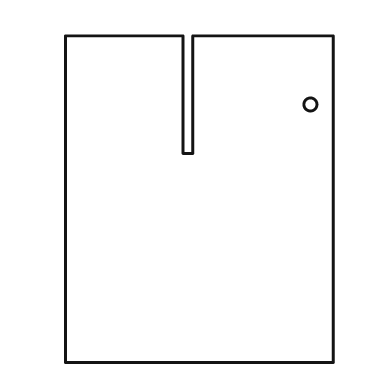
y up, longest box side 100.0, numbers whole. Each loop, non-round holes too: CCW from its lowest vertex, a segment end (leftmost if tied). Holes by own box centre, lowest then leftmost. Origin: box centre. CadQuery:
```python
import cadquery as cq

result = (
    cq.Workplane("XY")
    .moveTo(-41.0, -50.0)
    .lineTo(41.0, -50.0)
    .lineTo(41.0, 50.0)
    .lineTo(-2.0, 50.0)
    .lineTo(-2.0, 14.0)
    .lineTo(-5.0, 14.0)
    .lineTo(-5.0, 50.0)
    .lineTo(-41.0, 50.0)
    .close()
    .moveTo(34.0, 29.0)
    .circle(2.0)
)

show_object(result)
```